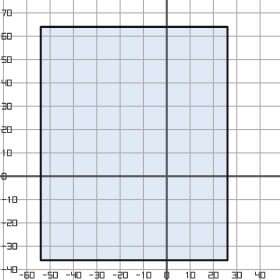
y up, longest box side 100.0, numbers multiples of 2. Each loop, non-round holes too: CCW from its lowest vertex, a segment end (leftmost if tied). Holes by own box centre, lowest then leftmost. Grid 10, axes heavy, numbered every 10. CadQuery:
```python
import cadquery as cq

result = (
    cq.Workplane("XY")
    .moveTo(-54.0, -36.0)
    .lineTo(26.0, -36.0)
    .lineTo(26.0, 64.0)
    .lineTo(-54.0, 64.0)
    .close()
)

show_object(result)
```